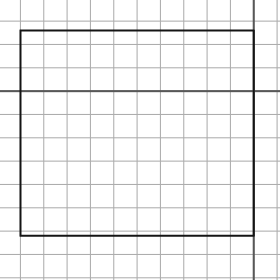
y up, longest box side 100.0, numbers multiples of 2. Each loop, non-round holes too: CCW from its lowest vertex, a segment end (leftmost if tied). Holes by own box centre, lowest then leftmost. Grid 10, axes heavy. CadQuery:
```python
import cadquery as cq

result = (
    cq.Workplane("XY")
    .moveTo(-100.0, -62.0)
    .lineTo(0.0, -62.0)
    .lineTo(0.0, 26.0)
    .lineTo(-100.0, 26.0)
    .close()
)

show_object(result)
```